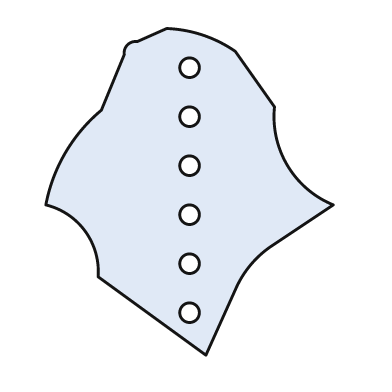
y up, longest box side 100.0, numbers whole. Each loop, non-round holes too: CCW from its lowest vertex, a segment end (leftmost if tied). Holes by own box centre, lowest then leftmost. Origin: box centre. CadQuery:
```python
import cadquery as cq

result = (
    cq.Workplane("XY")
    .moveTo(5.0, -50.0)
    .lineTo(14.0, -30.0)
    .threePointArc((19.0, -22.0), (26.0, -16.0))
    .lineTo(44.0, -4.0)
    .threePointArc((30.0, 8.0), (26.0, 26.0))
    .lineTo(14.0, 43.0)
    .threePointArc((4.0, 48.0), (-7.0, 50.0))
    .lineTo(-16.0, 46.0)
    .threePointArc((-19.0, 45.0), (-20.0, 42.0))
    .lineTo(-27.0, 25.0)
    .threePointArc((-38.0, 12.0), (-44.0, -4.0))
    .threePointArc((-32.0, -12.0), (-28.0, -26.0))
    .close()
    .moveTo(0.0, -37.0)
    .circle(3.0)
    .moveTo(0.0, -22.0)
    .circle(3.0)
    .moveTo(0.0, -7.0)
    .circle(3.0)
    .moveTo(0.0, 8.0)
    .circle(3.0)
    .moveTo(0.0, 23.0)
    .circle(3.0)
    .moveTo(0.0, 38.0)
    .circle(3.0)
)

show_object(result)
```